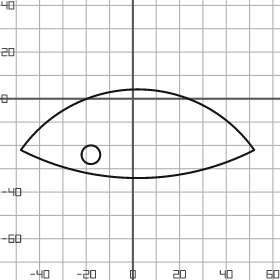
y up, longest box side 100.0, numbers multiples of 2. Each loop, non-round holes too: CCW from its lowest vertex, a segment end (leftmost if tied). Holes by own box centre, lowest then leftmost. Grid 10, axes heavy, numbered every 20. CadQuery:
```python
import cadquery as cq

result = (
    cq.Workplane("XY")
    .moveTo(-48.0, -22.0)
    .threePointArc((2.0, -34.0), (52.0, -22.0))
    .threePointArc((2.0, 4.0), (-48.0, -22.0))
    .close()
    .moveTo(-18.0, -24.0)
    .circle(4.0)
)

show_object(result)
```